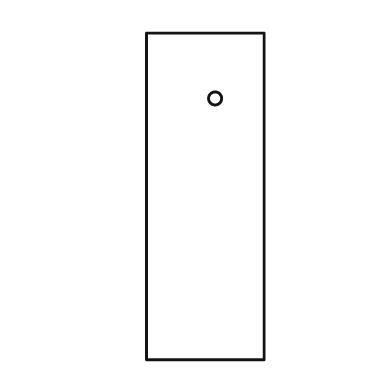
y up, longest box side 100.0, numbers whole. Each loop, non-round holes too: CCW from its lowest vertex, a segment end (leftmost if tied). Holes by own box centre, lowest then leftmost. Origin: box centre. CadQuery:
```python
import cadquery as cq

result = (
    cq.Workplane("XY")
    .moveTo(-18.0, -50.0)
    .lineTo(18.0, -50.0)
    .lineTo(18.0, 50.0)
    .lineTo(-18.0, 50.0)
    .close()
    .moveTo(3.0, 30.0)
    .circle(2.0)
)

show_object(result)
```